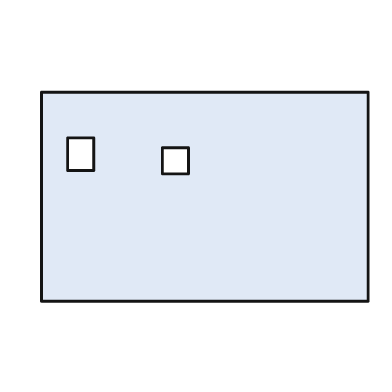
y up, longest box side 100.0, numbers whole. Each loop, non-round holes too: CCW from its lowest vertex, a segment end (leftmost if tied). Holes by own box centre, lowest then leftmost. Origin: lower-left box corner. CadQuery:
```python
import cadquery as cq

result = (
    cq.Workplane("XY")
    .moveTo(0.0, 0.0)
    .lineTo(100.0, 0.0)
    .lineTo(100.0, 64.0)
    .lineTo(0.0, 64.0)
    .close()
    .moveTo(37.0, 39.0)
    .lineTo(45.0, 39.0)
    .lineTo(45.0, 47.0)
    .lineTo(37.0, 47.0)
    .close()
    .moveTo(8.0, 40.0)
    .lineTo(16.0, 40.0)
    .lineTo(16.0, 50.0)
    .lineTo(8.0, 50.0)
    .close()
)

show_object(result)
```